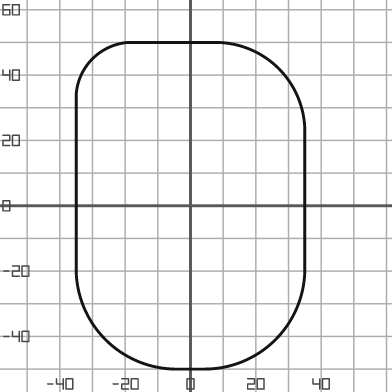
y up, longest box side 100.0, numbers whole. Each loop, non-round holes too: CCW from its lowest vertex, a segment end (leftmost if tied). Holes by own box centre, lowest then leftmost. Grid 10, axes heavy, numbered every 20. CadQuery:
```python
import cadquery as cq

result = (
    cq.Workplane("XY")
    .moveTo(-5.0, -50.0)
    .lineTo(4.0, -50.0)
    .threePointArc((26.0, -41.0), (35.0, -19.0))
    .lineTo(35.0, 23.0)
    .threePointArc((27.0, 42.0), (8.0, 50.0))
    .lineTo(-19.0, 50.0)
    .threePointArc((-30.0, 45.0), (-35.0, 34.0))
    .lineTo(-35.0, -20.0)
    .threePointArc((-26.0, -41.0), (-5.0, -50.0))
    .close()
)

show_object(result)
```